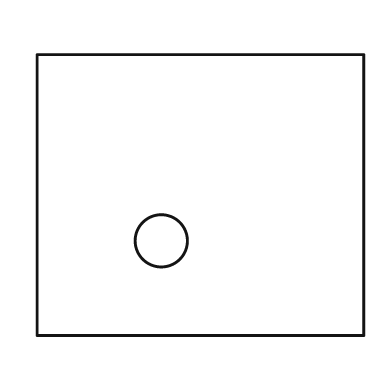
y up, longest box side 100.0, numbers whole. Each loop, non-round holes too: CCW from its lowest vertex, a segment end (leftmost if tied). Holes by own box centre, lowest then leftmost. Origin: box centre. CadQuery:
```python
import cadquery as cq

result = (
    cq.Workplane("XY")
    .moveTo(-50.0, -43.0)
    .lineTo(50.0, -43.0)
    .lineTo(50.0, 43.0)
    .lineTo(-50.0, 43.0)
    .close()
    .moveTo(-12.0, -14.0)
    .circle(8.0)
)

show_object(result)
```